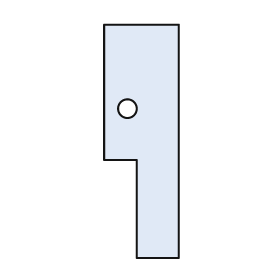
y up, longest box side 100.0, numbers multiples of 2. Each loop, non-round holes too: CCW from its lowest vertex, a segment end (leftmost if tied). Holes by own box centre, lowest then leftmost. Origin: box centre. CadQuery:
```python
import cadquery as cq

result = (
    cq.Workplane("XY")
    .moveTo(-2.0, -50.0)
    .lineTo(16.0, -50.0)
    .lineTo(16.0, 50.0)
    .lineTo(-16.0, 50.0)
    .lineTo(-16.0, -8.0)
    .lineTo(-2.0, -8.0)
    .close()
    .moveTo(-6.0, 14.0)
    .circle(4.0)
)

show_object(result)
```